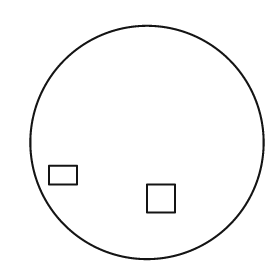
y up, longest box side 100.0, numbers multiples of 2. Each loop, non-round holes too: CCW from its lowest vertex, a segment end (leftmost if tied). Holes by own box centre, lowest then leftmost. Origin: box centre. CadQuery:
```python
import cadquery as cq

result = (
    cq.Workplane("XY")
    .moveTo(0.0, 0.0)
    .circle(50.0)
    .moveTo(0.0, -30.0)
    .lineTo(12.0, -30.0)
    .lineTo(12.0, -18.0)
    .lineTo(0.0, -18.0)
    .close()
    .moveTo(-42.0, -18.0)
    .lineTo(-30.0, -18.0)
    .lineTo(-30.0, -10.0)
    .lineTo(-42.0, -10.0)
    .close()
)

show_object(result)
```